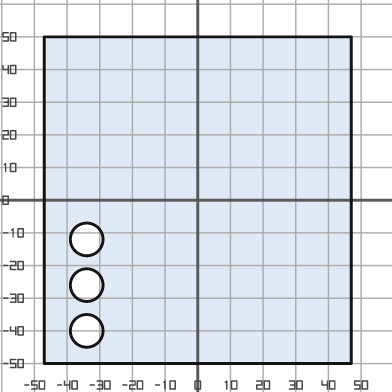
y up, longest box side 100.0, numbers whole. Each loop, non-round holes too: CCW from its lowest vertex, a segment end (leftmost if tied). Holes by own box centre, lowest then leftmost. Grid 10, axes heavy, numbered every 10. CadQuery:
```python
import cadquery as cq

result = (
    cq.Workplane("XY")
    .moveTo(-47.0, -50.0)
    .lineTo(47.0, -50.0)
    .lineTo(47.0, 50.0)
    .lineTo(-47.0, 50.0)
    .close()
    .moveTo(-34.0, -40.0)
    .circle(5.0)
    .moveTo(-34.0, -26.0)
    .circle(5.0)
    .moveTo(-34.0, -12.0)
    .circle(5.0)
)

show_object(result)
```